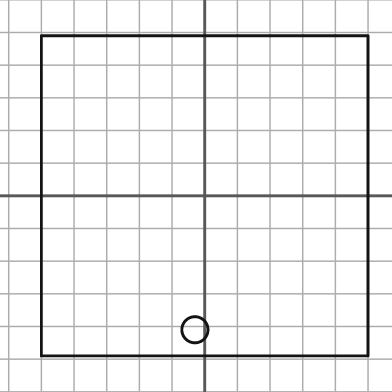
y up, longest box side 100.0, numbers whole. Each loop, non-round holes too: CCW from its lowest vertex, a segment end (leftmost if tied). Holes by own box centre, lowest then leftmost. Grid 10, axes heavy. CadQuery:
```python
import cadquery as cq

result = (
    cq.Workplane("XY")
    .moveTo(-50.0, -49.0)
    .lineTo(50.0, -49.0)
    .lineTo(50.0, 49.0)
    .lineTo(-50.0, 49.0)
    .close()
    .moveTo(-3.0, -41.0)
    .circle(4.0)
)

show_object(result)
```